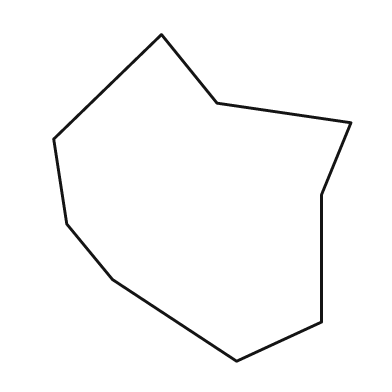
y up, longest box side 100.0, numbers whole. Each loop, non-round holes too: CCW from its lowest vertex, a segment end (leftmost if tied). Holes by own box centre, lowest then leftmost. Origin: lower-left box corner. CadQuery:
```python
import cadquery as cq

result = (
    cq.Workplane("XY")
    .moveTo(56.0, 0.0)
    .lineTo(82.0, 12.0)
    .lineTo(82.0, 51.0)
    .lineTo(91.0, 73.0)
    .lineTo(50.0, 79.0)
    .lineTo(33.0, 100.0)
    .lineTo(0.0, 68.0)
    .lineTo(4.0, 42.0)
    .lineTo(18.0, 25.0)
    .close()
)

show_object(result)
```